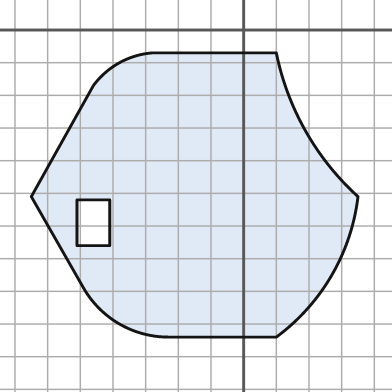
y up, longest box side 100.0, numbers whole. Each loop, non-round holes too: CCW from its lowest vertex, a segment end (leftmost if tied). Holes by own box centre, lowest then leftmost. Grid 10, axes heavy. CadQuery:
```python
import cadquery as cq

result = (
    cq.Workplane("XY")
    .moveTo(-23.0, -94.0)
    .lineTo(10.0, -94.0)
    .threePointArc((27.0, -75.0), (35.0, -51.0))
    .threePointArc((19.0, -31.0), (10.0, -7.0))
    .lineTo(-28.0, -7.0)
    .threePointArc((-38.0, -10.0), (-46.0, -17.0))
    .lineTo(-65.0, -51.0)
    .lineTo(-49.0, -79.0)
    .threePointArc((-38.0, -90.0), (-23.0, -94.0))
    .close()
    .moveTo(-51.0, -66.0)
    .lineTo(-41.0, -66.0)
    .lineTo(-41.0, -52.0)
    .lineTo(-51.0, -52.0)
    .close()
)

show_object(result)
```